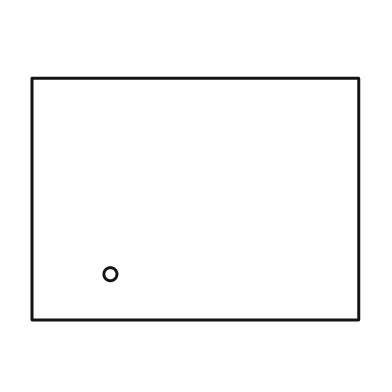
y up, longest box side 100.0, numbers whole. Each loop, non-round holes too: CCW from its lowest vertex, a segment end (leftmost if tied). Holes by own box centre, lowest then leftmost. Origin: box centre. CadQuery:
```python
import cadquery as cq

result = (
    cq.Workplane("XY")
    .moveTo(-50.0, -37.0)
    .lineTo(50.0, -37.0)
    .lineTo(50.0, 37.0)
    .lineTo(-50.0, 37.0)
    .close()
    .moveTo(-26.0, -23.0)
    .circle(2.0)
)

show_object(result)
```